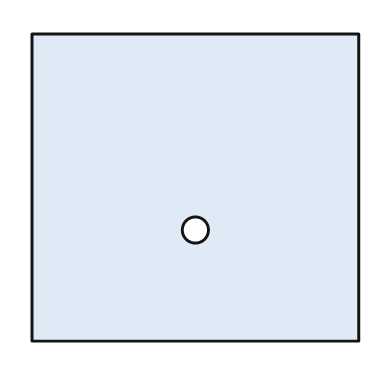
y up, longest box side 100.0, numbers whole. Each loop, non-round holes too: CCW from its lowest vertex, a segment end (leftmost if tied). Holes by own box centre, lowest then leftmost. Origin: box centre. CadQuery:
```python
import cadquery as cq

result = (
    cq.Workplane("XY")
    .moveTo(-50.0, -47.0)
    .lineTo(50.0, -47.0)
    .lineTo(50.0, 47.0)
    .lineTo(-50.0, 47.0)
    .close()
    .moveTo(0.0, -13.0)
    .circle(4.0)
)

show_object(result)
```